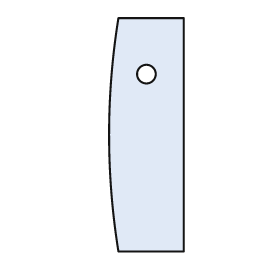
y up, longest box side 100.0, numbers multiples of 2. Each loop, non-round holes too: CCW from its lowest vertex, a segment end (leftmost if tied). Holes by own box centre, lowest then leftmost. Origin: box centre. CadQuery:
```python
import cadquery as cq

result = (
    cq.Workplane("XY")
    .moveTo(-12.0, -50.0)
    .lineTo(16.0, -50.0)
    .lineTo(16.0, 50.0)
    .lineTo(-12.0, 50.0)
    .threePointArc((-16.0, 0.0), (-12.0, -50.0))
    .close()
    .moveTo(0.0, 26.0)
    .circle(4.0)
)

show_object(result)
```